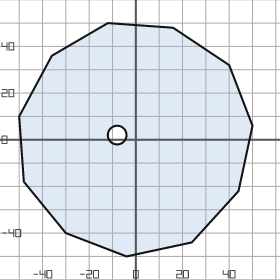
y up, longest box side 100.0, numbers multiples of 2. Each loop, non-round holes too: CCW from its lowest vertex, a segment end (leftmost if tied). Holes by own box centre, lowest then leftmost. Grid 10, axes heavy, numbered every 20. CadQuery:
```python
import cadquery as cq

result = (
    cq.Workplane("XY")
    .moveTo(-4.0, -50.0)
    .lineTo(24.0, -44.0)
    .lineTo(44.0, -22.0)
    .lineTo(50.0, 6.0)
    .lineTo(40.0, 32.0)
    .lineTo(16.0, 48.0)
    .lineTo(-12.0, 50.0)
    .lineTo(-36.0, 36.0)
    .lineTo(-50.0, 10.0)
    .lineTo(-48.0, -18.0)
    .lineTo(-30.0, -40.0)
    .close()
    .moveTo(-8.0, 2.0)
    .circle(4.0)
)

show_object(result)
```